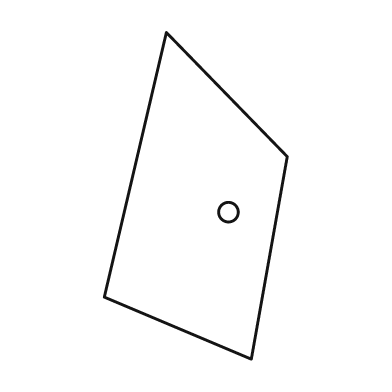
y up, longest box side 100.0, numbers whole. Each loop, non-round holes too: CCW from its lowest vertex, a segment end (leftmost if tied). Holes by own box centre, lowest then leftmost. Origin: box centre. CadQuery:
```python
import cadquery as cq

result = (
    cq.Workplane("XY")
    .moveTo(17.0, -50.0)
    .lineTo(28.0, 12.0)
    .lineTo(-9.0, 50.0)
    .lineTo(-28.0, -31.0)
    .close()
    .moveTo(10.0, -5.0)
    .circle(3.0)
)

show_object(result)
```